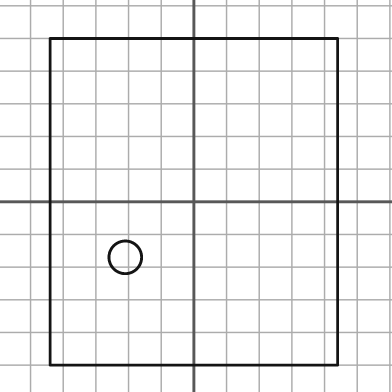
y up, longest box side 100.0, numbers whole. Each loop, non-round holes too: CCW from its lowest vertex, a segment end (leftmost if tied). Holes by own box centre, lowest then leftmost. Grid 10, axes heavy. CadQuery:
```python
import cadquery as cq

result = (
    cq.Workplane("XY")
    .moveTo(-44.0, -50.0)
    .lineTo(44.0, -50.0)
    .lineTo(44.0, 50.0)
    .lineTo(-44.0, 50.0)
    .close()
    .moveTo(-21.0, -17.0)
    .circle(5.0)
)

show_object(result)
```